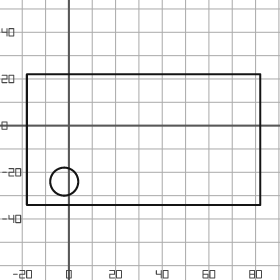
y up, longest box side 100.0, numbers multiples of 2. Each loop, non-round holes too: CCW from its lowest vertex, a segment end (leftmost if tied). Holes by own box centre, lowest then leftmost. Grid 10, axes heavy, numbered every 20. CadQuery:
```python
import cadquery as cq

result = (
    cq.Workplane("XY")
    .moveTo(-18.0, -34.0)
    .lineTo(82.0, -34.0)
    .lineTo(82.0, 22.0)
    .lineTo(-18.0, 22.0)
    .close()
    .moveTo(-2.0, -24.0)
    .circle(6.0)
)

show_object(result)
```